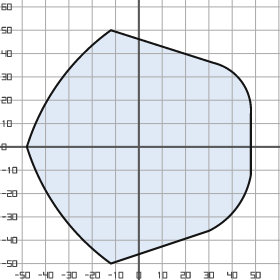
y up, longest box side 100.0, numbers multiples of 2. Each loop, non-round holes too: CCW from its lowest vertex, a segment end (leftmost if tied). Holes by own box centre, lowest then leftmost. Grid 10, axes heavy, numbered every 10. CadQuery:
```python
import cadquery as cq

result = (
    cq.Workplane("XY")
    .moveTo(-12.0, -50.0)
    .lineTo(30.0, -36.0)
    .threePointArc((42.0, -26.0), (48.0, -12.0))
    .lineTo(48.0, 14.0)
    .threePointArc((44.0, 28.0), (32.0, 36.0))
    .lineTo(-12.0, 50.0)
    .threePointArc((-34.0, 28.0), (-48.0, 0.0))
    .threePointArc((-34.0, -28.0), (-12.0, -50.0))
    .close()
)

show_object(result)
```